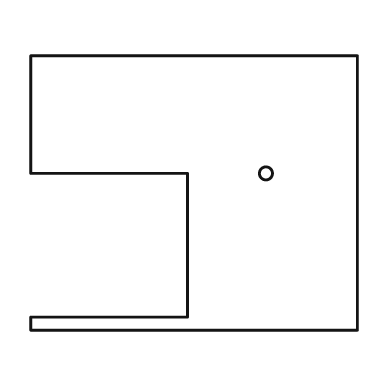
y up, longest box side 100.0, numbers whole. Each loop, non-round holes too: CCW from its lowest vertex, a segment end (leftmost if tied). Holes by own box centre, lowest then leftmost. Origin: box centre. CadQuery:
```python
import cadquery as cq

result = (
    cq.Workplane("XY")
    .moveTo(-50.0, -42.0)
    .lineTo(50.0, -42.0)
    .lineTo(50.0, 42.0)
    .lineTo(-50.0, 42.0)
    .lineTo(-50.0, 6.0)
    .lineTo(-2.0, 6.0)
    .lineTo(-2.0, -38.0)
    .lineTo(-50.0, -38.0)
    .close()
    .moveTo(22.0, 6.0)
    .circle(2.0)
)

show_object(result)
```